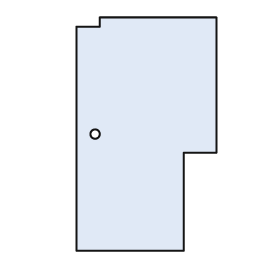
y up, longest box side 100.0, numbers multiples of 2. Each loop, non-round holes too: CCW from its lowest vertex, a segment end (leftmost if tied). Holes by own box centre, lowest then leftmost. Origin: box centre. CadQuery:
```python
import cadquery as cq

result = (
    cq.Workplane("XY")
    .moveTo(-30.0, -50.0)
    .lineTo(16.0, -50.0)
    .lineTo(16.0, -8.0)
    .lineTo(30.0, -8.0)
    .lineTo(30.0, 50.0)
    .lineTo(-20.0, 50.0)
    .lineTo(-20.0, 46.0)
    .lineTo(-30.0, 46.0)
    .close()
    .moveTo(-22.0, 0.0)
    .circle(2.0)
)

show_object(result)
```